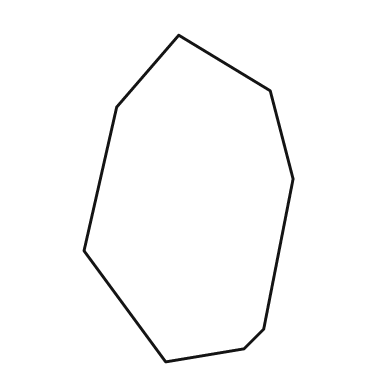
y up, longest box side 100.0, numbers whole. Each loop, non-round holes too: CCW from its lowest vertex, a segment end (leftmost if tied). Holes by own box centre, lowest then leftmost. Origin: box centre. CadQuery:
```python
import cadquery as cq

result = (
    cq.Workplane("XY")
    .moveTo(-7.0, -50.0)
    .lineTo(17.0, -46.0)
    .lineTo(23.0, -40.0)
    .lineTo(32.0, 6.0)
    .lineTo(25.0, 33.0)
    .lineTo(-3.0, 50.0)
    .lineTo(-22.0, 28.0)
    .lineTo(-32.0, -16.0)
    .close()
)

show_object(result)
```